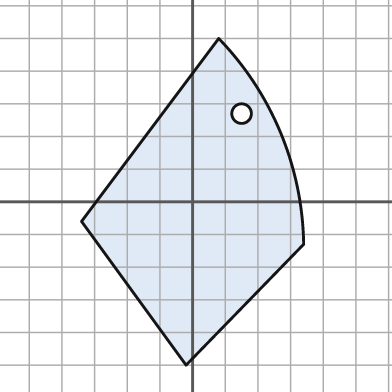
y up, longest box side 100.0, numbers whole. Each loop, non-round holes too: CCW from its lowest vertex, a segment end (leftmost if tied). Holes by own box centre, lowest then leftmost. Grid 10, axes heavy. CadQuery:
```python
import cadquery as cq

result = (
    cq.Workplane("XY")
    .moveTo(-2.0, -50.0)
    .lineTo(34.0, -13.0)
    .threePointArc((27.0, 21.0), (8.0, 50.0))
    .lineTo(-34.0, -6.0)
    .close()
    .moveTo(15.0, 27.0)
    .circle(3.0)
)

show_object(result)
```